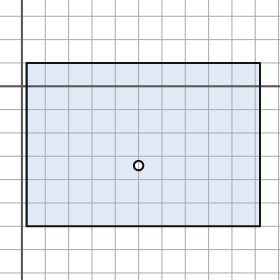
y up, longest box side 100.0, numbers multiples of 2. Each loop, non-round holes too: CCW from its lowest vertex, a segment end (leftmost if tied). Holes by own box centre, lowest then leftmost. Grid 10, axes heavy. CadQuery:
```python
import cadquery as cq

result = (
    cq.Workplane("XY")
    .moveTo(2.0, -60.0)
    .lineTo(102.0, -60.0)
    .lineTo(102.0, 10.0)
    .lineTo(2.0, 10.0)
    .close()
    .moveTo(50.0, -34.0)
    .circle(2.0)
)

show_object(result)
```